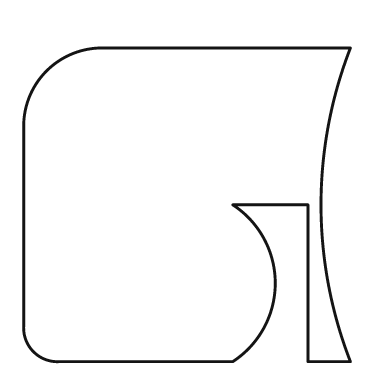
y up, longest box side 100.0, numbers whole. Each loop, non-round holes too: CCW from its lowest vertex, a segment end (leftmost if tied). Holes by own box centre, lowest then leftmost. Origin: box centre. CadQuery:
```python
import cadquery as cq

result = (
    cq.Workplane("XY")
    .moveTo(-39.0, -48.0)
    .lineTo(14.0, -48.0)
    .threePointArc((27.0, -24.0), (14.0, 0.0))
    .lineTo(37.0, 0.0)
    .lineTo(37.0, -48.0)
    .lineTo(50.0, -48.0)
    .threePointArc((41.0, 0.0), (50.0, 48.0))
    .lineTo(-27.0, 48.0)
    .threePointArc((-43.0, 41.0), (-50.0, 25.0))
    .lineTo(-50.0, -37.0)
    .threePointArc((-47.0, -45.0), (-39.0, -48.0))
    .close()
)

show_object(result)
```